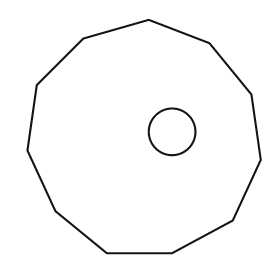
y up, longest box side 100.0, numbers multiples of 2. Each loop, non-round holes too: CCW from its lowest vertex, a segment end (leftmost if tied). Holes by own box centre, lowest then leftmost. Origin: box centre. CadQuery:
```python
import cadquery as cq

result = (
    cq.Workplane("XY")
    .moveTo(-16.0, -50.0)
    .lineTo(12.0, -50.0)
    .lineTo(38.0, -36.0)
    .lineTo(50.0, -10.0)
    .lineTo(46.0, 18.0)
    .lineTo(28.0, 40.0)
    .lineTo(2.0, 50.0)
    .lineTo(-26.0, 42.0)
    .lineTo(-46.0, 22.0)
    .lineTo(-50.0, -6.0)
    .lineTo(-38.0, -32.0)
    .close()
    .moveTo(12.0, 2.0)
    .circle(10.0)
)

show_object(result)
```